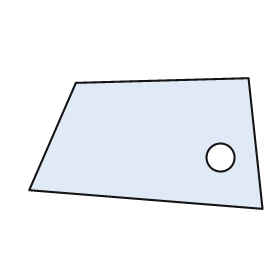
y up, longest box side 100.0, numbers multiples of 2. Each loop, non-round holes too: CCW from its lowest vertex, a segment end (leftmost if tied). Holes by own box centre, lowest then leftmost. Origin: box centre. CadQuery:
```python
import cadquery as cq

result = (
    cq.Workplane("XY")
    .moveTo(50.0, -28.0)
    .lineTo(44.0, 28.0)
    .lineTo(-30.0, 26.0)
    .lineTo(-50.0, -20.0)
    .close()
    .moveTo(32.0, -6.0)
    .circle(6.0)
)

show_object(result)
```